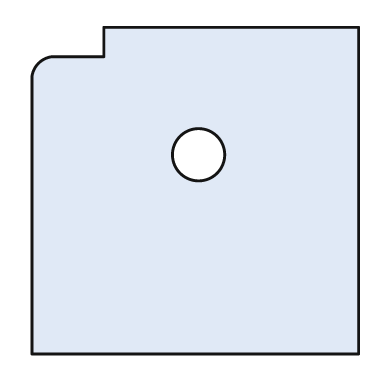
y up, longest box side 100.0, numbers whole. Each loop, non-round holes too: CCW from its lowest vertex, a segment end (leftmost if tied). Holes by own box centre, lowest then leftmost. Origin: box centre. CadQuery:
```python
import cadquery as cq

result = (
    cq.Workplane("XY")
    .moveTo(-50.0, -50.0)
    .lineTo(50.0, -50.0)
    .lineTo(50.0, 50.0)
    .lineTo(-28.0, 50.0)
    .lineTo(-28.0, 41.0)
    .lineTo(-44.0, 41.0)
    .threePointArc((-48.0, 39.0), (-50.0, 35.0))
    .close()
    .moveTo(1.0, 11.0)
    .circle(8.0)
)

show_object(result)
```